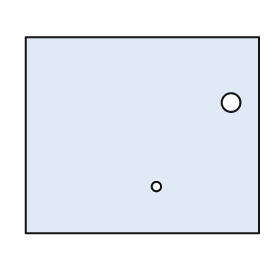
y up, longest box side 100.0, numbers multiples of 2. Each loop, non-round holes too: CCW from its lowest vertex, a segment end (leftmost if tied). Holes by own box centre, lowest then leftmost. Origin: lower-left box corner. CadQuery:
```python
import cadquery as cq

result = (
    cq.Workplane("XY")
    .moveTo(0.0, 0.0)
    .lineTo(100.0, 0.0)
    .lineTo(100.0, 84.0)
    .lineTo(0.0, 84.0)
    .close()
    .moveTo(56.0, 20.0)
    .circle(2.0)
    .moveTo(88.0, 56.0)
    .circle(4.0)
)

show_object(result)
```